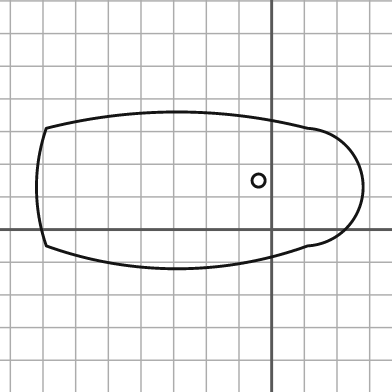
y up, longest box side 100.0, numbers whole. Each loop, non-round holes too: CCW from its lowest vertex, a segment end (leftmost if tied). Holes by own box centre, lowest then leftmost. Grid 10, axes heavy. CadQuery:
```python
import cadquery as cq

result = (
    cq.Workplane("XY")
    .moveTo(-69.0, -5.0)
    .threePointArc((-29.0, -12.0), (11.0, -5.0))
    .threePointArc((28.0, 13.0), (11.0, 31.0))
    .threePointArc((-29.0, 36.0), (-69.0, 31.0))
    .threePointArc((-72.0, 13.0), (-69.0, -5.0))
    .close()
    .moveTo(-4.0, 15.0)
    .circle(2.0)
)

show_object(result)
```